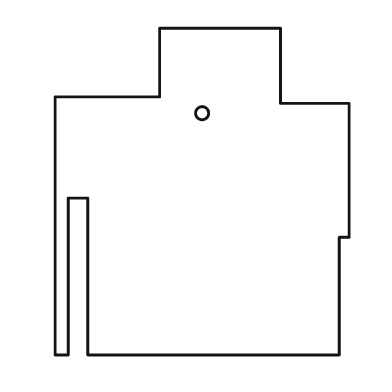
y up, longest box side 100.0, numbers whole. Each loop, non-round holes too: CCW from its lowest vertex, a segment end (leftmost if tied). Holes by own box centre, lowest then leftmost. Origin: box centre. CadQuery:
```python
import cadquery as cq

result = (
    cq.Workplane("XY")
    .moveTo(-45.0, -50.0)
    .lineTo(-41.0, -50.0)
    .lineTo(-41.0, -2.0)
    .lineTo(-35.0, -2.0)
    .lineTo(-35.0, -50.0)
    .lineTo(42.0, -50.0)
    .lineTo(42.0, -14.0)
    .lineTo(45.0, -14.0)
    .lineTo(45.0, 27.0)
    .lineTo(24.0, 27.0)
    .lineTo(24.0, 50.0)
    .lineTo(-13.0, 50.0)
    .lineTo(-13.0, 29.0)
    .lineTo(-45.0, 29.0)
    .close()
    .moveTo(0.0, 24.0)
    .circle(2.0)
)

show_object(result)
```